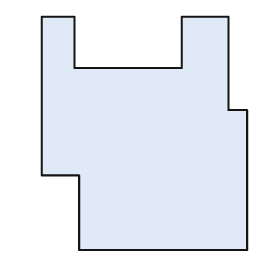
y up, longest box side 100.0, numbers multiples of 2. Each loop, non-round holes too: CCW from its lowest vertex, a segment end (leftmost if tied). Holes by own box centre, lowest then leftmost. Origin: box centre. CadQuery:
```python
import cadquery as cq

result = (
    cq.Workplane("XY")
    .moveTo(-28.0, -50.0)
    .lineTo(44.0, -50.0)
    .lineTo(44.0, 10.0)
    .lineTo(36.0, 10.0)
    .lineTo(36.0, 50.0)
    .lineTo(16.0, 50.0)
    .lineTo(16.0, 28.0)
    .lineTo(-30.0, 28.0)
    .lineTo(-30.0, 50.0)
    .lineTo(-44.0, 50.0)
    .lineTo(-44.0, -18.0)
    .lineTo(-28.0, -18.0)
    .close()
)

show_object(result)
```